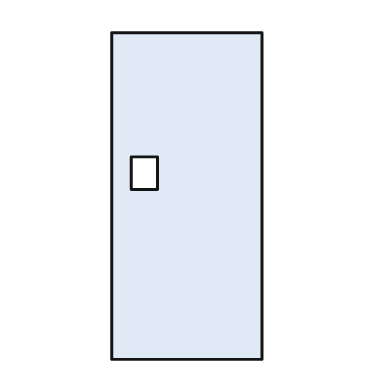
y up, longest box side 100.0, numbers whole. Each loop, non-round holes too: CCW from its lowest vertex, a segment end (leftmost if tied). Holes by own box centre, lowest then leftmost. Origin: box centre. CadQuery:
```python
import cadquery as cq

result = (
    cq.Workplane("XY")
    .moveTo(-23.0, -50.0)
    .lineTo(23.0, -50.0)
    .lineTo(23.0, 50.0)
    .lineTo(-23.0, 50.0)
    .close()
    .moveTo(-17.0, 2.0)
    .lineTo(-9.0, 2.0)
    .lineTo(-9.0, 12.0)
    .lineTo(-17.0, 12.0)
    .close()
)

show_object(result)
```